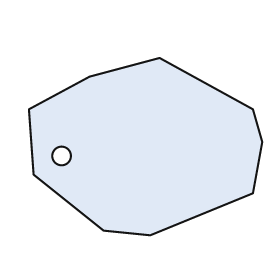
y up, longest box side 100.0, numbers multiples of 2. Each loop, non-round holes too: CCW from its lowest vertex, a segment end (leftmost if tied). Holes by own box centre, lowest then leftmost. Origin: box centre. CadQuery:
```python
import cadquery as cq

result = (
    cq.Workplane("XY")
    .moveTo(2.0, -38.0)
    .lineTo(46.0, -20.0)
    .lineTo(50.0, 2.0)
    .lineTo(46.0, 16.0)
    .lineTo(6.0, 38.0)
    .lineTo(-24.0, 30.0)
    .lineTo(-50.0, 16.0)
    .lineTo(-48.0, -12.0)
    .lineTo(-18.0, -36.0)
    .close()
    .moveTo(-36.0, -4.0)
    .circle(4.0)
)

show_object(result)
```